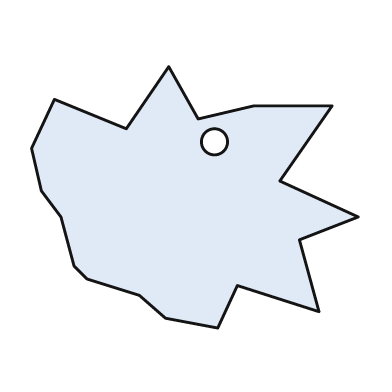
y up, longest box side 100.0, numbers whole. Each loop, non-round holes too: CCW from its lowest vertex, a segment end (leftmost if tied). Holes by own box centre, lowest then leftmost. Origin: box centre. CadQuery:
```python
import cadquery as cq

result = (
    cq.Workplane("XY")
    .moveTo(7.0, -40.0)
    .lineTo(13.0, -27.0)
    .lineTo(38.0, -35.0)
    .lineTo(32.0, -13.0)
    .lineTo(50.0, -6.0)
    .lineTo(26.0, 5.0)
    .lineTo(42.0, 28.0)
    .lineTo(18.0, 28.0)
    .lineTo(1.0, 24.0)
    .lineTo(-8.0, 40.0)
    .lineTo(-21.0, 21.0)
    .lineTo(-43.0, 30.0)
    .lineTo(-50.0, 15.0)
    .lineTo(-47.0, 2.0)
    .lineTo(-41.0, -6.0)
    .lineTo(-37.0, -21.0)
    .lineTo(-33.0, -25.0)
    .lineTo(-17.0, -30.0)
    .lineTo(-9.0, -37.0)
    .close()
    .moveTo(6.0, 17.0)
    .circle(4.0)
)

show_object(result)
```